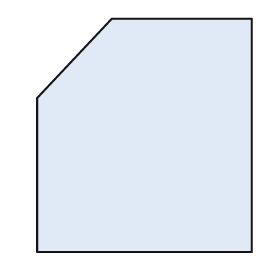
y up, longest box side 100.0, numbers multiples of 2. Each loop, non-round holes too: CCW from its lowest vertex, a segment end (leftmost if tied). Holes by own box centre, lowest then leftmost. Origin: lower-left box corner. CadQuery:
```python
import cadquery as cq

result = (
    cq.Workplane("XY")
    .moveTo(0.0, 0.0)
    .lineTo(92.0, 0.0)
    .lineTo(92.0, 100.0)
    .lineTo(32.0, 100.0)
    .lineTo(0.0, 66.0)
    .close()
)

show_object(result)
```